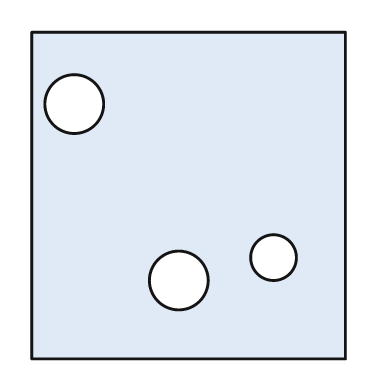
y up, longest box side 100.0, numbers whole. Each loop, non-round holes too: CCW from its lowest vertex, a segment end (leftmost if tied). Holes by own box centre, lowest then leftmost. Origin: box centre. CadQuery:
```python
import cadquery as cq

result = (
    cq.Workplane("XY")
    .moveTo(-48.0, -50.0)
    .lineTo(48.0, -50.0)
    .lineTo(48.0, 50.0)
    .lineTo(-48.0, 50.0)
    .close()
    .moveTo(-3.0, -26.0)
    .circle(9.0)
    .moveTo(26.0, -19.0)
    .circle(7.0)
    .moveTo(-35.0, 28.0)
    .circle(9.0)
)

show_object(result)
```